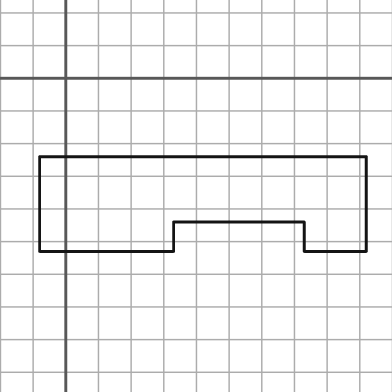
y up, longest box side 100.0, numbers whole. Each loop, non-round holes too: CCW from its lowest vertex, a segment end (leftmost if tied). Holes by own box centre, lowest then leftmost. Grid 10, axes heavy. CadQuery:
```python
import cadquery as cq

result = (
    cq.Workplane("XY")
    .moveTo(-8.0, -53.0)
    .lineTo(33.0, -53.0)
    .lineTo(33.0, -44.0)
    .lineTo(73.0, -44.0)
    .lineTo(73.0, -53.0)
    .lineTo(92.0, -53.0)
    .lineTo(92.0, -24.0)
    .lineTo(-8.0, -24.0)
    .close()
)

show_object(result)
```